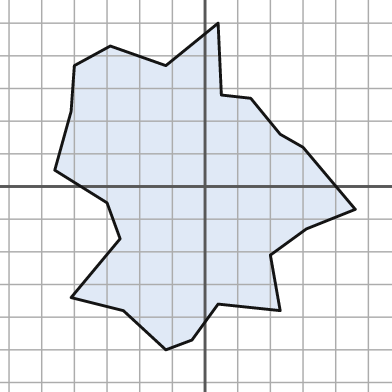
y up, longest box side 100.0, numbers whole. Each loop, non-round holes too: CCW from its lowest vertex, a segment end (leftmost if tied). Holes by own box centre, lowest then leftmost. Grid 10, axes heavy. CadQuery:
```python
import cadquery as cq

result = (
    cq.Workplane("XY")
    .moveTo(-12.0, -50.0)
    .lineTo(-4.0, -47.0)
    .lineTo(4.0, -36.0)
    .lineTo(23.0, -38.0)
    .lineTo(20.0, -21.0)
    .lineTo(31.0, -13.0)
    .lineTo(46.0, -7.0)
    .lineTo(30.0, 12.0)
    .lineTo(23.0, 16.0)
    .lineTo(14.0, 27.0)
    .lineTo(5.0, 28.0)
    .lineTo(4.0, 50.0)
    .lineTo(-12.0, 37.0)
    .lineTo(-29.0, 43.0)
    .lineTo(-40.0, 37.0)
    .lineTo(-41.0, 23.0)
    .lineTo(-46.0, 5.0)
    .lineTo(-30.0, -5.0)
    .lineTo(-26.0, -16.0)
    .lineTo(-41.0, -34.0)
    .lineTo(-25.0, -38.0)
    .close()
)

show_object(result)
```